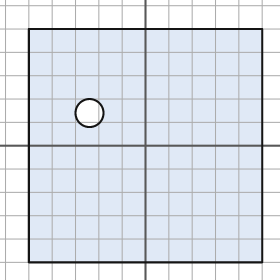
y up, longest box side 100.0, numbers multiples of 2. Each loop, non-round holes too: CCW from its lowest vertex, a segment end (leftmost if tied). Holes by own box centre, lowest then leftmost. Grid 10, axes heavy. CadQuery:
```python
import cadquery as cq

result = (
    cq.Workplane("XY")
    .moveTo(-50.0, -50.0)
    .lineTo(50.0, -50.0)
    .lineTo(50.0, 50.0)
    .lineTo(-50.0, 50.0)
    .close()
    .moveTo(-24.0, 14.0)
    .circle(6.0)
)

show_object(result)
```